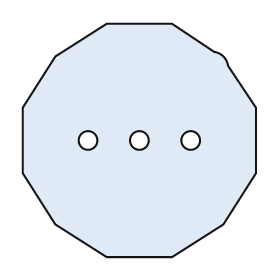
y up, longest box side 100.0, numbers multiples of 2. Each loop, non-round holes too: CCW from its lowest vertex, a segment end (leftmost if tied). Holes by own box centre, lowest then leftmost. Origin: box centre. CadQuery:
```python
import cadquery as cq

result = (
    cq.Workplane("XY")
    .moveTo(-14.0, -50.0)
    .lineTo(14.0, -50.0)
    .lineTo(36.0, -36.0)
    .lineTo(50.0, -14.0)
    .lineTo(50.0, 14.0)
    .lineTo(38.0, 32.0)
    .threePointArc((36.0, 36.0), (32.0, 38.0))
    .lineTo(14.0, 50.0)
    .lineTo(-14.0, 50.0)
    .lineTo(-36.0, 36.0)
    .lineTo(-50.0, 14.0)
    .lineTo(-50.0, -14.0)
    .lineTo(-36.0, -36.0)
    .close()
    .moveTo(-22.0, 0.0)
    .circle(4.0)
    .moveTo(0.0, 0.0)
    .circle(4.0)
    .moveTo(22.0, 0.0)
    .circle(4.0)
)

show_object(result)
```